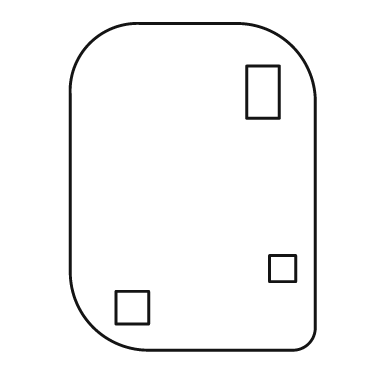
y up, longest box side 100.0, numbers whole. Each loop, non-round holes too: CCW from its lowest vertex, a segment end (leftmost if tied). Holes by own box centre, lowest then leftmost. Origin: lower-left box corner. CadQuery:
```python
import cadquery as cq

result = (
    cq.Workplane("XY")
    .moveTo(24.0, 0.0)
    .lineTo(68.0, 0.0)
    .threePointArc((73.0, 2.0), (75.0, 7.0))
    .lineTo(75.0, 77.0)
    .threePointArc((68.0, 93.0), (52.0, 100.0))
    .lineTo(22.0, 100.0)
    .threePointArc((6.0, 94.0), (0.0, 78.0))
    .lineTo(0.0, 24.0)
    .threePointArc((7.0, 7.0), (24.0, 0.0))
    .close()
    .moveTo(14.0, 8.0)
    .lineTo(24.0, 8.0)
    .lineTo(24.0, 18.0)
    .lineTo(14.0, 18.0)
    .close()
    .moveTo(61.0, 21.0)
    .lineTo(69.0, 21.0)
    .lineTo(69.0, 29.0)
    .lineTo(61.0, 29.0)
    .close()
    .moveTo(54.0, 71.0)
    .lineTo(64.0, 71.0)
    .lineTo(64.0, 87.0)
    .lineTo(54.0, 87.0)
    .close()
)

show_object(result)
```